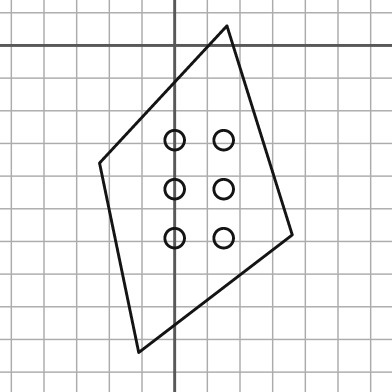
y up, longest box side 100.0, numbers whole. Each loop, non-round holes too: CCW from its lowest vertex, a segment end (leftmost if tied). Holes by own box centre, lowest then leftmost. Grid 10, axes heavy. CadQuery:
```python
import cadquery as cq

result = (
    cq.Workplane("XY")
    .moveTo(-11.0, -94.0)
    .lineTo(36.0, -58.0)
    .lineTo(16.0, 6.0)
    .lineTo(-23.0, -36.0)
    .close()
    .moveTo(0.0, -59.0)
    .circle(3.0)
    .moveTo(15.0, -59.0)
    .circle(3.0)
    .moveTo(0.0, -44.0)
    .circle(3.0)
    .moveTo(15.0, -44.0)
    .circle(3.0)
    .moveTo(0.0, -29.0)
    .circle(3.0)
    .moveTo(15.0, -29.0)
    .circle(3.0)
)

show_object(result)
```